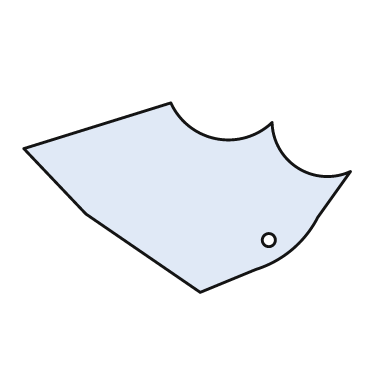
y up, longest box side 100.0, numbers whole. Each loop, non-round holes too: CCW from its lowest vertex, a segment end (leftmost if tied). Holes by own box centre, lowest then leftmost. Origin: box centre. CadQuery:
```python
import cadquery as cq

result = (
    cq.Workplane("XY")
    .moveTo(4.0, -29.0)
    .lineTo(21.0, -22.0)
    .threePointArc((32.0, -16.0), (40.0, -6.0))
    .lineTo(50.0, 8.0)
    .threePointArc((34.0, 9.0), (26.0, 23.0))
    .threePointArc((9.0, 18.0), (-5.0, 29.0))
    .lineTo(-50.0, 15.0)
    .lineTo(-31.0, -5.0)
    .close()
    .moveTo(25.0, -13.0)
    .circle(2.0)
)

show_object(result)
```